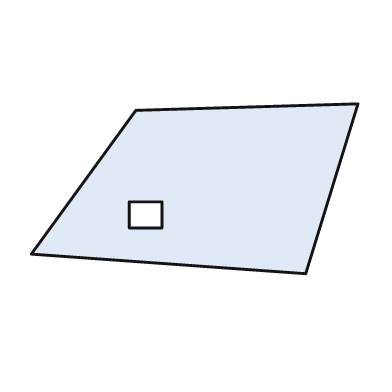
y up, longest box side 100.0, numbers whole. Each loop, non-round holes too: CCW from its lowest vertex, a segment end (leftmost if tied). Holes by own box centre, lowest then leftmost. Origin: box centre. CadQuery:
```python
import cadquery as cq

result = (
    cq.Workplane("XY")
    .moveTo(34.0, -26.0)
    .lineTo(50.0, 26.0)
    .lineTo(-18.0, 24.0)
    .lineTo(-50.0, -20.0)
    .close()
    .moveTo(-20.0, -12.0)
    .lineTo(-10.0, -12.0)
    .lineTo(-10.0, -4.0)
    .lineTo(-20.0, -4.0)
    .close()
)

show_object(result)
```